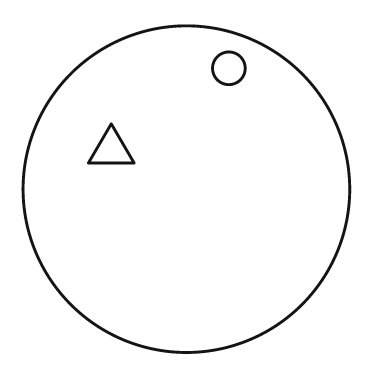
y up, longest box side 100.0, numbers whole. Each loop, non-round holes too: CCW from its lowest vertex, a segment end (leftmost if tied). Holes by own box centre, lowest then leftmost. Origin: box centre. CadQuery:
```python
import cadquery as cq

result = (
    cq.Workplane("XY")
    .moveTo(0.0, 0.0)
    .circle(50.0)
    .moveTo(-30.0, 8.0)
    .lineTo(-16.0, 8.0)
    .lineTo(-23.0, 20.0)
    .close()
    .moveTo(13.0, 37.0)
    .circle(5.0)
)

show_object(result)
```